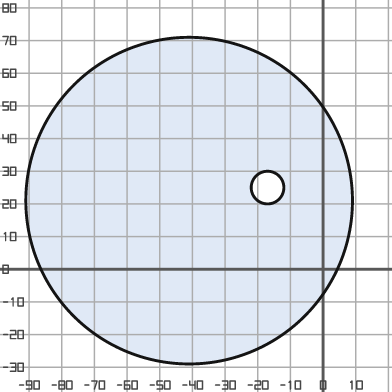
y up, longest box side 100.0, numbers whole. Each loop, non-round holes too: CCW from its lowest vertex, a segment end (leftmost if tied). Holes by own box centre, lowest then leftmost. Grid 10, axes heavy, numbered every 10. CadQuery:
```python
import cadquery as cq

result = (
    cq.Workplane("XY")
    .moveTo(-41.0, 21.0)
    .circle(50.0)
    .moveTo(-17.0, 25.0)
    .circle(5.0)
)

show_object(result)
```